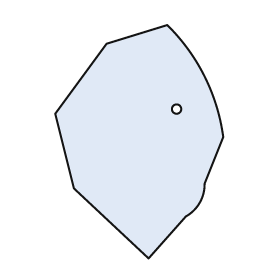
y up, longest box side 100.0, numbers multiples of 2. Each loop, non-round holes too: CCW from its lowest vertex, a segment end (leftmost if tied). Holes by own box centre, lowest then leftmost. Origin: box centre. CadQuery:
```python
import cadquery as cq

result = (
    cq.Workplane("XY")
    .moveTo(4.0, -50.0)
    .lineTo(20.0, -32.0)
    .threePointArc((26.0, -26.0), (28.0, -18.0))
    .lineTo(36.0, 2.0)
    .threePointArc((28.0, 28.0), (12.0, 50.0))
    .lineTo(-14.0, 42.0)
    .lineTo(-36.0, 12.0)
    .lineTo(-28.0, -20.0)
    .close()
    .moveTo(16.0, 14.0)
    .circle(2.0)
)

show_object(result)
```